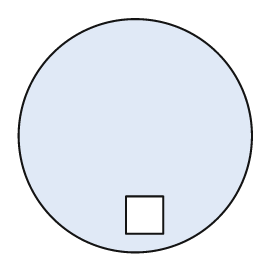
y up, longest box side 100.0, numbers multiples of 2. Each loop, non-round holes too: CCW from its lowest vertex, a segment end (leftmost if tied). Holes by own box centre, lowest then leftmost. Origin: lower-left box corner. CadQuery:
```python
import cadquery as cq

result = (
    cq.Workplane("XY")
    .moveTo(50.0, 50.0)
    .circle(50.0)
    .moveTo(46.0, 8.0)
    .lineTo(62.0, 8.0)
    .lineTo(62.0, 24.0)
    .lineTo(46.0, 24.0)
    .close()
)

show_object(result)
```